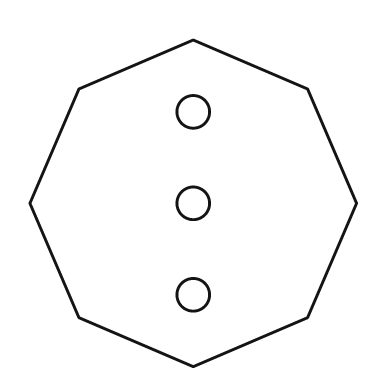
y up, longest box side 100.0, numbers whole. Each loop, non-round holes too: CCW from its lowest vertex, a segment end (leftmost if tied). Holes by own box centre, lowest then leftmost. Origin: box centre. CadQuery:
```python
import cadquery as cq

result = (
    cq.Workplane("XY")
    .moveTo(0.0, -50.0)
    .lineTo(35.0, -35.0)
    .lineTo(50.0, 0.0)
    .lineTo(35.0, 35.0)
    .lineTo(0.0, 50.0)
    .lineTo(-35.0, 35.0)
    .lineTo(-50.0, 0.0)
    .lineTo(-35.0, -35.0)
    .close()
    .moveTo(0.0, -28.0)
    .circle(5.0)
    .moveTo(0.0, 0.0)
    .circle(5.0)
    .moveTo(0.0, 28.0)
    .circle(5.0)
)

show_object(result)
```